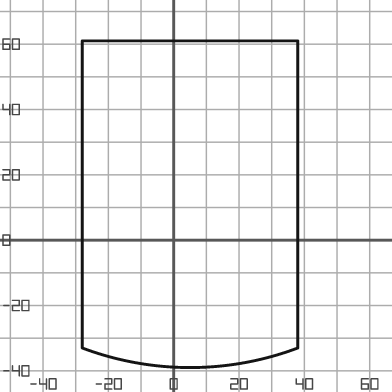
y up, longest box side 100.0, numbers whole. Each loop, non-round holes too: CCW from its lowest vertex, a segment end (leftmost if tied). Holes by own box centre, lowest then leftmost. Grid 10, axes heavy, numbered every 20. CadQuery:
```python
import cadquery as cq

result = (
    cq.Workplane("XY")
    .moveTo(-28.0, -33.0)
    .threePointArc((5.0, -39.0), (38.0, -33.0))
    .lineTo(38.0, 61.0)
    .lineTo(-28.0, 61.0)
    .close()
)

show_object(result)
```